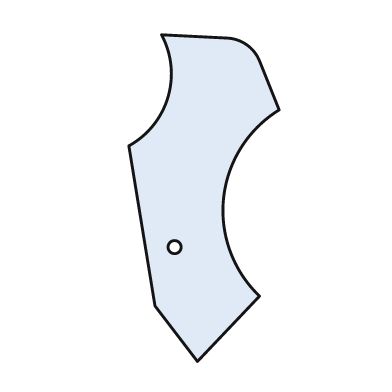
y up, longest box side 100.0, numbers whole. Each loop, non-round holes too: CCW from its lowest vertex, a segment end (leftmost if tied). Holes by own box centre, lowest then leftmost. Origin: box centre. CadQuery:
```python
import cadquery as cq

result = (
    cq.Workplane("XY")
    .moveTo(-2.0, -50.0)
    .lineTo(17.0, -30.0)
    .threePointArc((6.0, 0.0), (23.0, 27.0))
    .lineTo(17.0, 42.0)
    .threePointArc((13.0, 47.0), (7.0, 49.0))
    .lineTo(-13.0, 50.0)
    .threePointArc((-11.0, 31.0), (-23.0, 16.0))
    .lineTo(-15.0, -33.0)
    .close()
    .moveTo(-9.0, -15.0)
    .circle(2.0)
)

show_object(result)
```